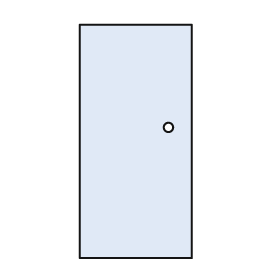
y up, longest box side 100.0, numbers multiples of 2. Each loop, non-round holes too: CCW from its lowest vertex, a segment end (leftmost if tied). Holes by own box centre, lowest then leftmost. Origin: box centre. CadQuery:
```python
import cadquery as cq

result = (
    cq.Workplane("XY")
    .moveTo(-24.0, -50.0)
    .lineTo(24.0, -50.0)
    .lineTo(24.0, 50.0)
    .lineTo(-24.0, 50.0)
    .close()
    .moveTo(14.0, 6.0)
    .circle(2.0)
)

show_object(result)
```